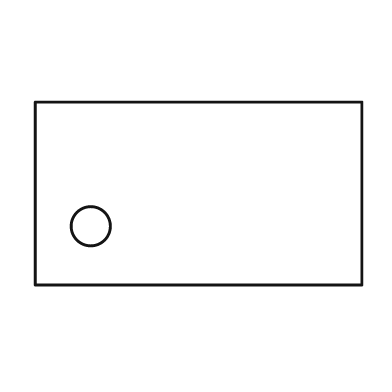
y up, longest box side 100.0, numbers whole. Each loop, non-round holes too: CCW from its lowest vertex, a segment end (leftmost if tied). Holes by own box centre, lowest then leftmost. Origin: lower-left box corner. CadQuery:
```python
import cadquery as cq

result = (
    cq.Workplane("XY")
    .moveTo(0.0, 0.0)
    .lineTo(100.0, 0.0)
    .lineTo(100.0, 56.0)
    .lineTo(0.0, 56.0)
    .close()
    .moveTo(17.0, 18.0)
    .circle(6.0)
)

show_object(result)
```